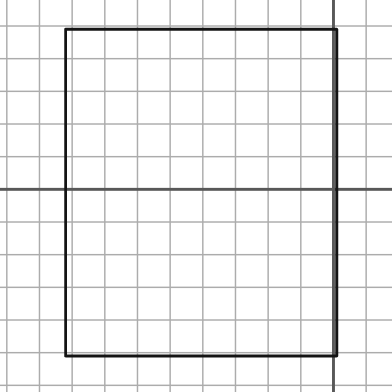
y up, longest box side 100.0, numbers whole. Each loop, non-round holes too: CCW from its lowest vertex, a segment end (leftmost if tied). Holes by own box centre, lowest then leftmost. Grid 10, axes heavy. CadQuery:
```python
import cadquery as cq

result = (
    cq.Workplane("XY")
    .moveTo(-82.0, -51.0)
    .lineTo(1.0, -51.0)
    .lineTo(1.0, 49.0)
    .lineTo(-82.0, 49.0)
    .close()
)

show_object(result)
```